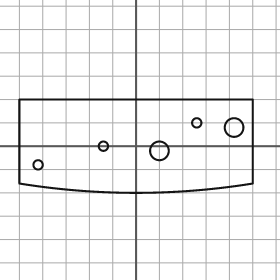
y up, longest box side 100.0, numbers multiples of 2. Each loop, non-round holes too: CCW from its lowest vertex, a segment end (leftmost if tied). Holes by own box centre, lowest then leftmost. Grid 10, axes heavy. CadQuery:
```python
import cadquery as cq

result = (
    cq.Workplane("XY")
    .moveTo(-50.0, -16.0)
    .threePointArc((0.0, -20.0), (50.0, -16.0))
    .lineTo(50.0, 20.0)
    .lineTo(-50.0, 20.0)
    .close()
    .moveTo(-42.0, -8.0)
    .circle(2.0)
    .moveTo(10.0, -2.0)
    .circle(4.0)
    .moveTo(-14.0, 0.0)
    .circle(2.0)
    .moveTo(42.0, 8.0)
    .circle(4.0)
    .moveTo(26.0, 10.0)
    .circle(2.0)
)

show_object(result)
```